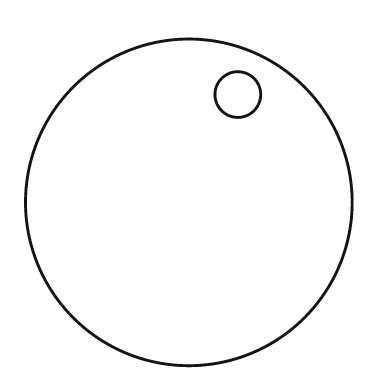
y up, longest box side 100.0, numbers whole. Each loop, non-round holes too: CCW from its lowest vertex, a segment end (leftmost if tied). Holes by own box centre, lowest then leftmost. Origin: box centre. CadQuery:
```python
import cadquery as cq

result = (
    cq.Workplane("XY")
    .moveTo(0.0, 0.0)
    .circle(50.0)
    .moveTo(15.0, 33.0)
    .circle(7.0)
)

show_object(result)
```